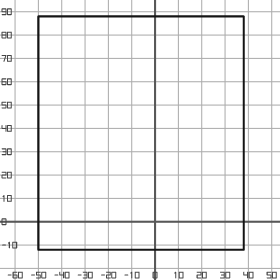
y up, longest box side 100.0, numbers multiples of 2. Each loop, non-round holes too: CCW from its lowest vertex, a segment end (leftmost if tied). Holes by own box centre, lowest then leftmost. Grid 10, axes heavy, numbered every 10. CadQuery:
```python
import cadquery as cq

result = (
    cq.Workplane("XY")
    .moveTo(-50.0, -12.0)
    .lineTo(38.0, -12.0)
    .lineTo(38.0, 88.0)
    .lineTo(-50.0, 88.0)
    .close()
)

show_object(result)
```